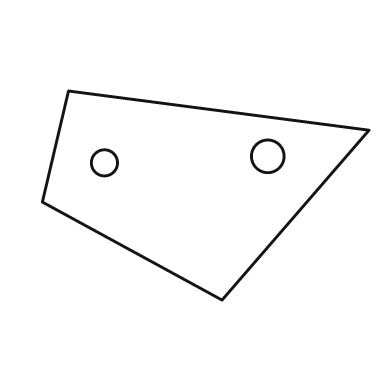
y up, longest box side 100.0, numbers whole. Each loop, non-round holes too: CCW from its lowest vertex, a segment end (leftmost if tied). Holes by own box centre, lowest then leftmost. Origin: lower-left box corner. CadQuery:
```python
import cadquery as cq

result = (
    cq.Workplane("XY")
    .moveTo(55.0, 0.0)
    .lineTo(100.0, 52.0)
    .lineTo(8.0, 64.0)
    .lineTo(0.0, 30.0)
    .close()
    .moveTo(19.0, 42.0)
    .circle(4.0)
    .moveTo(69.0, 44.0)
    .circle(5.0)
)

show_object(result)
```